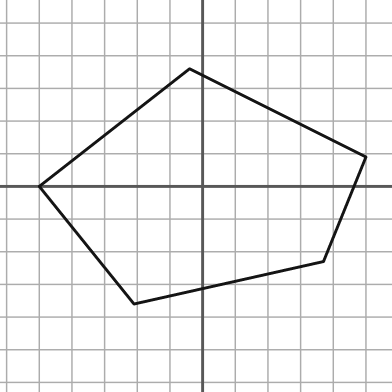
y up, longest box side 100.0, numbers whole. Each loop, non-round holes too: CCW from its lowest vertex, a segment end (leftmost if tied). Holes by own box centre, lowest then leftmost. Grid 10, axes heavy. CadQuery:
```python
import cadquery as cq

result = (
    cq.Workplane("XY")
    .moveTo(-21.0, -36.0)
    .lineTo(37.0, -23.0)
    .lineTo(50.0, 9.0)
    .lineTo(-4.0, 36.0)
    .lineTo(-50.0, 0.0)
    .close()
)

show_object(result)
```